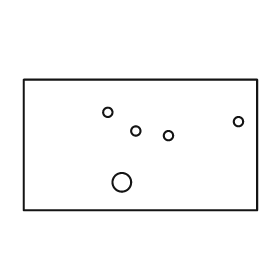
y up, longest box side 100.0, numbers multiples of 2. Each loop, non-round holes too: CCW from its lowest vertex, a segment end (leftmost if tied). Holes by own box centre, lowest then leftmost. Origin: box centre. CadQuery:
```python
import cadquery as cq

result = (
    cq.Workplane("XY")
    .moveTo(-50.0, -28.0)
    .lineTo(50.0, -28.0)
    .lineTo(50.0, 28.0)
    .lineTo(-50.0, 28.0)
    .close()
    .moveTo(-8.0, -16.0)
    .circle(4.0)
    .moveTo(12.0, 4.0)
    .circle(2.0)
    .moveTo(-2.0, 6.0)
    .circle(2.0)
    .moveTo(42.0, 10.0)
    .circle(2.0)
    .moveTo(-14.0, 14.0)
    .circle(2.0)
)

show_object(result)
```